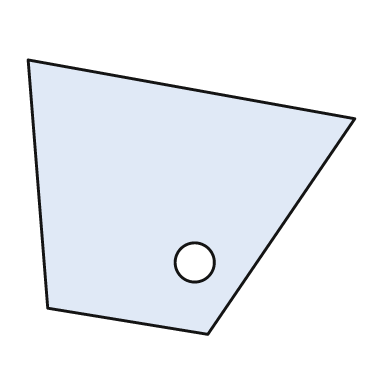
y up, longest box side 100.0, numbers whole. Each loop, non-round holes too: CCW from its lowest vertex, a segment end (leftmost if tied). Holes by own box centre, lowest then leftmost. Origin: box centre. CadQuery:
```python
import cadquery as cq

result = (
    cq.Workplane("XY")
    .moveTo(5.0, -42.0)
    .lineTo(50.0, 24.0)
    .lineTo(-50.0, 42.0)
    .lineTo(-44.0, -34.0)
    .close()
    .moveTo(1.0, -20.0)
    .circle(6.0)
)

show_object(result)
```